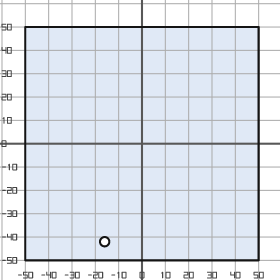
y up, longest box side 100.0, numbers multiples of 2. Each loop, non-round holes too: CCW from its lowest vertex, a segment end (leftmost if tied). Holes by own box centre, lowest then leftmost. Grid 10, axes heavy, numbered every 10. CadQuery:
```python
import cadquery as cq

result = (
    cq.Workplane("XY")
    .moveTo(-50.0, -50.0)
    .lineTo(50.0, -50.0)
    .lineTo(50.0, 50.0)
    .lineTo(-50.0, 50.0)
    .close()
    .moveTo(-16.0, -42.0)
    .circle(2.0)
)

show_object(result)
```